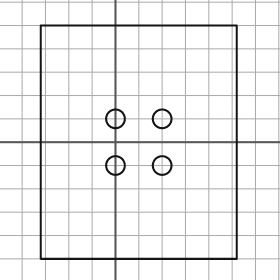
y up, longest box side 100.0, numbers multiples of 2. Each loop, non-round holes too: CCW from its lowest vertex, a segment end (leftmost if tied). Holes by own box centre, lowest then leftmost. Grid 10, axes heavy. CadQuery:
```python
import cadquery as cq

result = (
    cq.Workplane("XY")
    .moveTo(-32.0, -50.0)
    .lineTo(52.0, -50.0)
    .lineTo(52.0, 50.0)
    .lineTo(-32.0, 50.0)
    .close()
    .moveTo(0.0, -10.0)
    .circle(4.0)
    .moveTo(20.0, -10.0)
    .circle(4.0)
    .moveTo(0.0, 10.0)
    .circle(4.0)
    .moveTo(20.0, 10.0)
    .circle(4.0)
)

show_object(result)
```